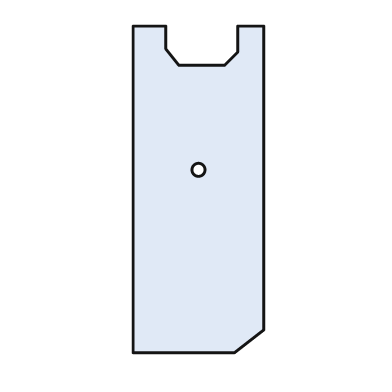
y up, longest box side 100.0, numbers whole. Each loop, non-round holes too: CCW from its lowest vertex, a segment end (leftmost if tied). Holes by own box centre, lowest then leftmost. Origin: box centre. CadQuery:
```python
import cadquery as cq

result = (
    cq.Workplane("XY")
    .moveTo(-20.0, -50.0)
    .lineTo(11.0, -50.0)
    .lineTo(20.0, -43.0)
    .lineTo(20.0, 50.0)
    .lineTo(12.0, 50.0)
    .lineTo(12.0, 42.0)
    .lineTo(8.0, 38.0)
    .lineTo(-6.0, 38.0)
    .lineTo(-10.0, 43.0)
    .lineTo(-10.0, 50.0)
    .lineTo(-20.0, 50.0)
    .close()
    .moveTo(0.0, 6.0)
    .circle(2.0)
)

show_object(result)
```